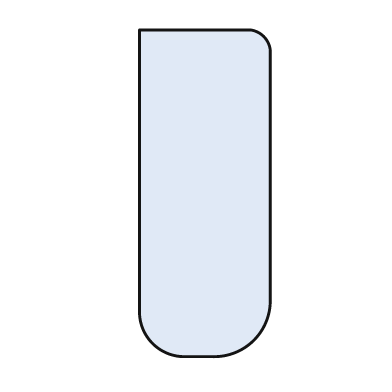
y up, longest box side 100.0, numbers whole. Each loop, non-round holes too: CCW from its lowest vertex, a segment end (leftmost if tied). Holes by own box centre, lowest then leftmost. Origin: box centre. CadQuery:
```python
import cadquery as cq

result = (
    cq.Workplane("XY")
    .moveTo(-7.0, -50.0)
    .lineTo(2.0, -50.0)
    .threePointArc((15.0, -45.0), (20.0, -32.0))
    .lineTo(20.0, 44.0)
    .threePointArc((18.0, 48.0), (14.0, 50.0))
    .lineTo(-20.0, 50.0)
    .lineTo(-20.0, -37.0)
    .threePointArc((-16.0, -46.0), (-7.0, -50.0))
    .close()
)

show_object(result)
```